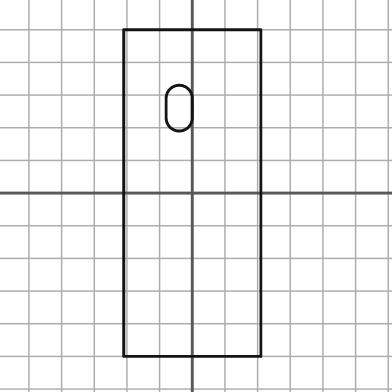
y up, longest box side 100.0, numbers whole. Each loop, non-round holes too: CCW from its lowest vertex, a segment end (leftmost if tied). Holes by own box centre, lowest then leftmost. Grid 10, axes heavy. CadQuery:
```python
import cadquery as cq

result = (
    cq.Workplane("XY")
    .moveTo(-21.0, -50.0)
    .lineTo(21.0, -50.0)
    .lineTo(21.0, 50.0)
    .lineTo(-21.0, 50.0)
    .close()
    .moveTo(-8.0, 23.0)
    .threePointArc((-4.0, 19.0), (0.0, 23.0))
    .lineTo(0.0, 29.0)
    .threePointArc((-4.0, 33.0), (-8.0, 29.0))
    .close()
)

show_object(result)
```